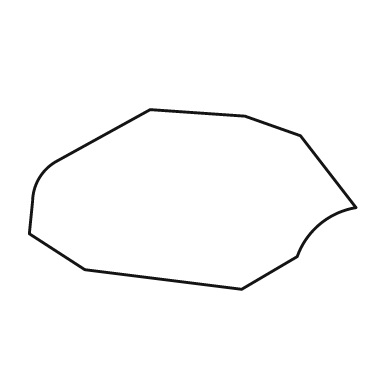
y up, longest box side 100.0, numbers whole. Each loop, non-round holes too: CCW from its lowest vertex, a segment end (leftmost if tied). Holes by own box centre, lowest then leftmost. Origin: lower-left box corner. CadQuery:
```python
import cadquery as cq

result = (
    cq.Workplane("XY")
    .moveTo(65.0, 0.0)
    .lineTo(82.0, 10.0)
    .threePointArc((89.0, 20.0), (100.0, 25.0))
    .lineTo(83.0, 47.0)
    .lineTo(66.0, 53.0)
    .lineTo(37.0, 55.0)
    .lineTo(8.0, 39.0)
    .threePointArc((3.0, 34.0), (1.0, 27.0))
    .lineTo(0.0, 17.0)
    .lineTo(17.0, 6.0)
    .close()
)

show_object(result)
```